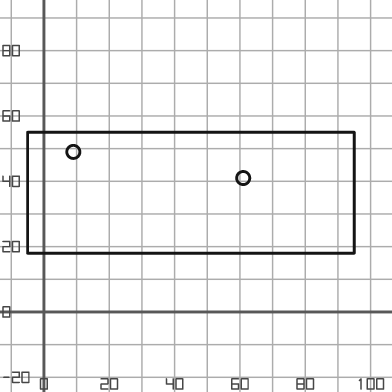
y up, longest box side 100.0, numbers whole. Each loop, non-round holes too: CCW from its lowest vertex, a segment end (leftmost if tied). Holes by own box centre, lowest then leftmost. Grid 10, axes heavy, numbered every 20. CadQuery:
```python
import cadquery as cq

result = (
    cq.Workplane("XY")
    .moveTo(-5.0, 18.0)
    .lineTo(95.0, 18.0)
    .lineTo(95.0, 55.0)
    .lineTo(-5.0, 55.0)
    .close()
    .moveTo(61.0, 41.0)
    .circle(2.0)
    .moveTo(9.0, 49.0)
    .circle(2.0)
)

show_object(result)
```